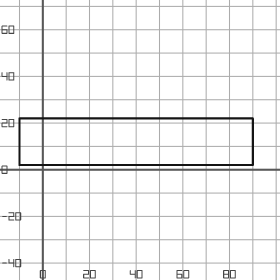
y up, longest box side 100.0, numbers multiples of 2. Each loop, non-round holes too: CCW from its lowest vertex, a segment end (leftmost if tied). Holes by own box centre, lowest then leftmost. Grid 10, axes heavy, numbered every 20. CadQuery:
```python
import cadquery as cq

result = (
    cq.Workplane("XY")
    .moveTo(-10.0, 2.0)
    .lineTo(90.0, 2.0)
    .lineTo(90.0, 22.0)
    .lineTo(-10.0, 22.0)
    .close()
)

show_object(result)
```